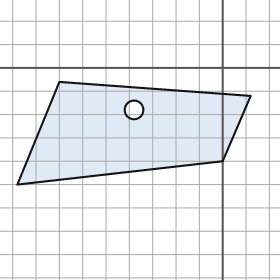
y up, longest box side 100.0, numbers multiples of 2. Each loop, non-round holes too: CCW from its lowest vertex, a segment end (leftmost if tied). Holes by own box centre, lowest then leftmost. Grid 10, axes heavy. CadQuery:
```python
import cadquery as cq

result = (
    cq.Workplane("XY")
    .moveTo(-88.0, -50.0)
    .lineTo(0.0, -40.0)
    .lineTo(12.0, -12.0)
    .lineTo(-70.0, -6.0)
    .close()
    .moveTo(-38.0, -18.0)
    .circle(4.0)
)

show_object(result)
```